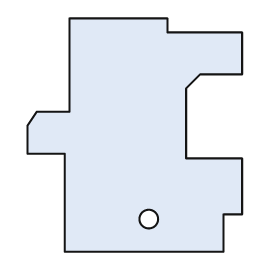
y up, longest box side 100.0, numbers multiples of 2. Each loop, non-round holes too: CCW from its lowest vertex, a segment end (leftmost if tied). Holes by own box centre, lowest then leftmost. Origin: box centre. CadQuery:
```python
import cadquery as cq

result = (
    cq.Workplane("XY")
    .moveTo(-30.0, -50.0)
    .lineTo(38.0, -50.0)
    .lineTo(38.0, -34.0)
    .lineTo(46.0, -34.0)
    .lineTo(46.0, -10.0)
    .lineTo(22.0, -10.0)
    .lineTo(22.0, 20.0)
    .lineTo(28.0, 26.0)
    .lineTo(46.0, 26.0)
    .lineTo(46.0, 44.0)
    .lineTo(14.0, 44.0)
    .lineTo(14.0, 50.0)
    .lineTo(-28.0, 50.0)
    .lineTo(-28.0, 10.0)
    .lineTo(-42.0, 10.0)
    .lineTo(-46.0, 4.0)
    .lineTo(-46.0, -8.0)
    .lineTo(-30.0, -8.0)
    .close()
    .moveTo(6.0, -36.0)
    .circle(4.0)
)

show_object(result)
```